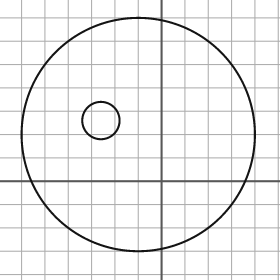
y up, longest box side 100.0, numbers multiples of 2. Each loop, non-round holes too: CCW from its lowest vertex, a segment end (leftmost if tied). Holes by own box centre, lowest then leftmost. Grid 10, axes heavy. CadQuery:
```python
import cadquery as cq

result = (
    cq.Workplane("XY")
    .moveTo(-10.0, 20.0)
    .circle(50.0)
    .moveTo(-26.0, 26.0)
    .circle(8.0)
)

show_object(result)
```